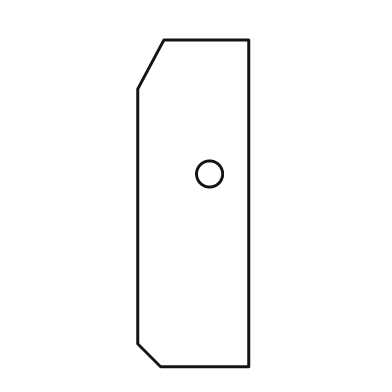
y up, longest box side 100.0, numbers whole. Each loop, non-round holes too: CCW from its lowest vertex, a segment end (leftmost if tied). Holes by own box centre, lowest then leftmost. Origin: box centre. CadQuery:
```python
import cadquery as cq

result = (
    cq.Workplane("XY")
    .moveTo(-10.0, -50.0)
    .lineTo(17.0, -50.0)
    .lineTo(17.0, 50.0)
    .lineTo(-9.0, 50.0)
    .lineTo(-17.0, 35.0)
    .lineTo(-17.0, -43.0)
    .close()
    .moveTo(5.0, 9.0)
    .circle(4.0)
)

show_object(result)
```